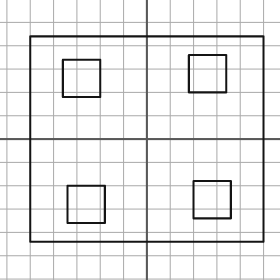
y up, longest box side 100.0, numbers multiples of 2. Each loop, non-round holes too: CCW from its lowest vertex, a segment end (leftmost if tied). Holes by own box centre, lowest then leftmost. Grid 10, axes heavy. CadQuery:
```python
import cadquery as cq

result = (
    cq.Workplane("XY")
    .moveTo(-50.0, -44.0)
    .lineTo(50.0, -44.0)
    .lineTo(50.0, 44.0)
    .lineTo(-50.0, 44.0)
    .close()
    .moveTo(-34.0, -36.0)
    .lineTo(-18.0, -36.0)
    .lineTo(-18.0, -20.0)
    .lineTo(-34.0, -20.0)
    .close()
    .moveTo(20.0, -34.0)
    .lineTo(36.0, -34.0)
    .lineTo(36.0, -18.0)
    .lineTo(20.0, -18.0)
    .close()
    .moveTo(-36.0, 18.0)
    .lineTo(-20.0, 18.0)
    .lineTo(-20.0, 34.0)
    .lineTo(-36.0, 34.0)
    .close()
    .moveTo(18.0, 20.0)
    .lineTo(34.0, 20.0)
    .lineTo(34.0, 36.0)
    .lineTo(18.0, 36.0)
    .close()
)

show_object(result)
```